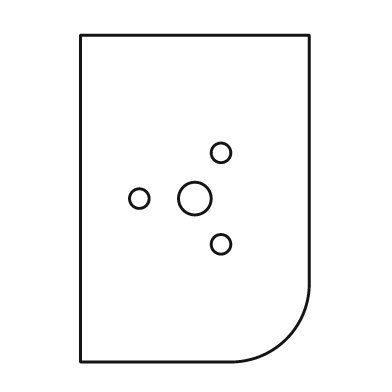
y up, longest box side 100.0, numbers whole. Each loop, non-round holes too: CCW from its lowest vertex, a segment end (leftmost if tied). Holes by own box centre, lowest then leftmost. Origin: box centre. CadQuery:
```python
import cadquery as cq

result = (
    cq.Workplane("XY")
    .moveTo(-35.0, -50.0)
    .lineTo(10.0, -50.0)
    .threePointArc((28.0, -43.0), (35.0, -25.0))
    .lineTo(35.0, 50.0)
    .lineTo(-35.0, 50.0)
    .close()
    .moveTo(8.0, -14.0)
    .circle(3.0)
    .moveTo(-17.0, 0.0)
    .circle(3.0)
    .moveTo(0.0, 0.0)
    .circle(5.0)
    .moveTo(8.0, 14.0)
    .circle(3.0)
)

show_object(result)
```